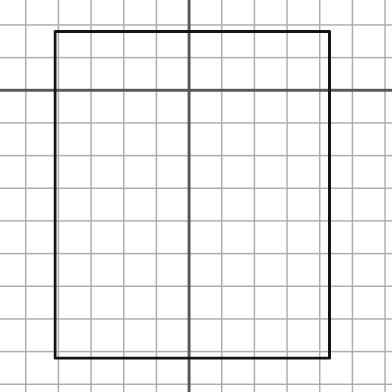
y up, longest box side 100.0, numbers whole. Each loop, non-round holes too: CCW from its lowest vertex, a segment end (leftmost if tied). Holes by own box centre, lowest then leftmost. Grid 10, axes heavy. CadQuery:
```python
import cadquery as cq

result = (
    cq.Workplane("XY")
    .moveTo(-41.0, -82.0)
    .lineTo(43.0, -82.0)
    .lineTo(43.0, 18.0)
    .lineTo(-41.0, 18.0)
    .close()
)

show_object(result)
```